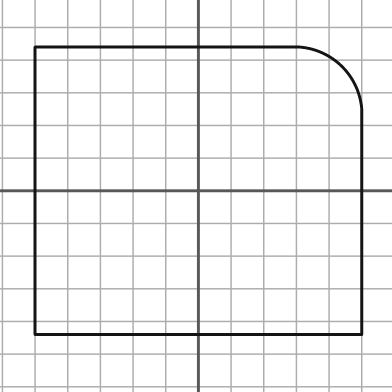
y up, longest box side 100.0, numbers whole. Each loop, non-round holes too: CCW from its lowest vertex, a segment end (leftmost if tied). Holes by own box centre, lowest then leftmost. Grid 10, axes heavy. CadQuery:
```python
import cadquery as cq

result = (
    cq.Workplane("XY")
    .moveTo(-50.0, -44.0)
    .lineTo(50.0, -44.0)
    .lineTo(50.0, 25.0)
    .threePointArc((44.0, 38.0), (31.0, 44.0))
    .lineTo(-50.0, 44.0)
    .close()
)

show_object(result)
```